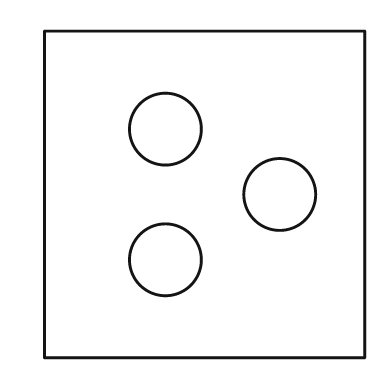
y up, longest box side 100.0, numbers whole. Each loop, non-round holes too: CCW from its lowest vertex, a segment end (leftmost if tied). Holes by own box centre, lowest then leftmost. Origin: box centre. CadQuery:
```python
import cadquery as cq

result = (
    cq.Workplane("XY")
    .moveTo(-49.0, -50.0)
    .lineTo(49.0, -50.0)
    .lineTo(49.0, 50.0)
    .lineTo(-49.0, 50.0)
    .close()
    .moveTo(-12.0, -20.0)
    .circle(11.0)
    .moveTo(23.0, 0.0)
    .circle(11.0)
    .moveTo(-12.0, 20.0)
    .circle(11.0)
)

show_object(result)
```